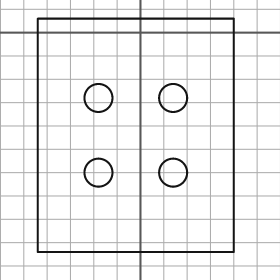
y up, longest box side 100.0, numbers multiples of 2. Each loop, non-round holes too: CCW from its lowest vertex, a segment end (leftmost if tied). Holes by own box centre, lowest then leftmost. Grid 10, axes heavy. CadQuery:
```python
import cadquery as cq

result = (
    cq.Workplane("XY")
    .moveTo(-44.0, -94.0)
    .lineTo(40.0, -94.0)
    .lineTo(40.0, 6.0)
    .lineTo(-44.0, 6.0)
    .close()
    .moveTo(-18.0, -60.0)
    .circle(6.0)
    .moveTo(14.0, -60.0)
    .circle(6.0)
    .moveTo(-18.0, -28.0)
    .circle(6.0)
    .moveTo(14.0, -28.0)
    .circle(6.0)
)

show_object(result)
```